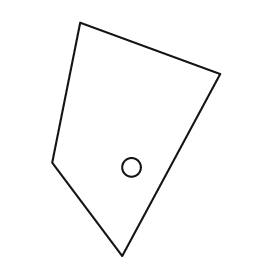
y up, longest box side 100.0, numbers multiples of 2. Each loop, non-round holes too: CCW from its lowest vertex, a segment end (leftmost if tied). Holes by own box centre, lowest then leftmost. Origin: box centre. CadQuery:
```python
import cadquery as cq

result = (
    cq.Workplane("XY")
    .moveTo(-6.0, -50.0)
    .lineTo(36.0, 28.0)
    .lineTo(-24.0, 50.0)
    .lineTo(-36.0, -10.0)
    .close()
    .moveTo(-2.0, -12.0)
    .circle(4.0)
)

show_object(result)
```